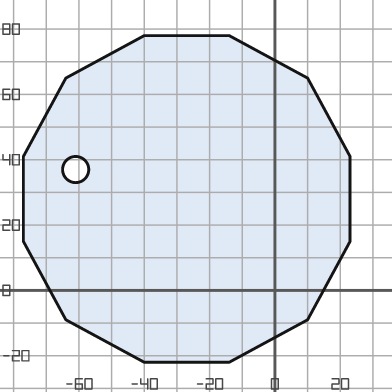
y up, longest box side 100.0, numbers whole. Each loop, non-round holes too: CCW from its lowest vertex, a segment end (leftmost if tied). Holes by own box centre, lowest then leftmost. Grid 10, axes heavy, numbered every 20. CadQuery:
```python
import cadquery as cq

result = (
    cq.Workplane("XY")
    .moveTo(-40.0, -22.0)
    .lineTo(-14.0, -22.0)
    .lineTo(10.0, -9.0)
    .lineTo(23.0, 15.0)
    .lineTo(23.0, 41.0)
    .lineTo(10.0, 65.0)
    .lineTo(-14.0, 78.0)
    .lineTo(-40.0, 78.0)
    .lineTo(-64.0, 65.0)
    .lineTo(-77.0, 41.0)
    .lineTo(-77.0, 15.0)
    .lineTo(-64.0, -9.0)
    .close()
    .moveTo(-61.0, 37.0)
    .circle(4.0)
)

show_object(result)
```